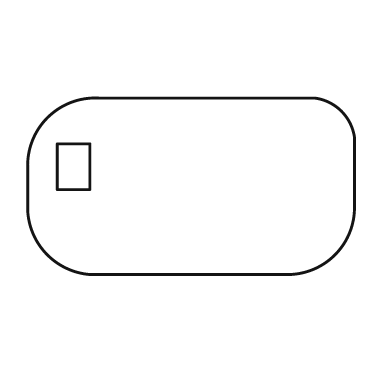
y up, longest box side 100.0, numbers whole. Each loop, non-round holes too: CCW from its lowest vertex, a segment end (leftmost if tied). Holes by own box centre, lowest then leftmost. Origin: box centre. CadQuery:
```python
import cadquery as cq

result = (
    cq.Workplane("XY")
    .moveTo(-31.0, -27.0)
    .lineTo(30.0, -27.0)
    .threePointArc((44.0, -21.0), (50.0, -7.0))
    .lineTo(50.0, 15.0)
    .threePointArc((46.0, 23.0), (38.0, 27.0))
    .lineTo(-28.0, 27.0)
    .threePointArc((-44.0, 21.0), (-50.0, 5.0))
    .lineTo(-50.0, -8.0)
    .threePointArc((-44.0, -21.0), (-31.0, -27.0))
    .close()
    .moveTo(-41.0, -1.0)
    .lineTo(-31.0, -1.0)
    .lineTo(-31.0, 13.0)
    .lineTo(-41.0, 13.0)
    .close()
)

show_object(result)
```